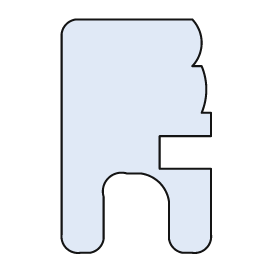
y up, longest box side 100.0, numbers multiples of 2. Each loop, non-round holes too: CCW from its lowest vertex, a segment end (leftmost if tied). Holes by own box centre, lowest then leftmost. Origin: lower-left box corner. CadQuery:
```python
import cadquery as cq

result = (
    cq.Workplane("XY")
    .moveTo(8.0, 0.0)
    .lineTo(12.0, 0.0)
    .threePointArc((16.0, 2.0), (18.0, 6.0))
    .lineTo(18.0, 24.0)
    .threePointArc((20.0, 32.0), (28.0, 34.0))
    .lineTo(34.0, 34.0)
    .threePointArc((42.0, 30.0), (46.0, 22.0))
    .lineTo(46.0, 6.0)
    .threePointArc((48.0, 2.0), (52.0, 0.0))
    .lineTo(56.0, 0.0)
    .threePointArc((62.0, 2.0), (64.0, 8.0))
    .lineTo(64.0, 36.0)
    .lineTo(42.0, 36.0)
    .lineTo(42.0, 50.0)
    .lineTo(64.0, 50.0)
    .lineTo(64.0, 60.0)
    .lineTo(60.0, 60.0)
    .threePointArc((62.0, 70.0), (60.0, 80.0))
    .lineTo(56.0, 80.0)
    .threePointArc((60.0, 90.0), (56.0, 100.0))
    .lineTo(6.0, 100.0)
    .threePointArc((2.0, 98.0), (0.0, 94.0))
    .lineTo(0.0, 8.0)
    .threePointArc((2.0, 2.0), (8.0, 0.0))
    .close()
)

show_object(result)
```